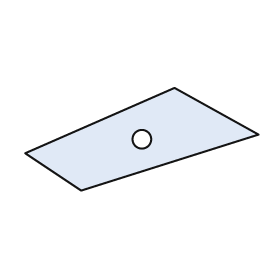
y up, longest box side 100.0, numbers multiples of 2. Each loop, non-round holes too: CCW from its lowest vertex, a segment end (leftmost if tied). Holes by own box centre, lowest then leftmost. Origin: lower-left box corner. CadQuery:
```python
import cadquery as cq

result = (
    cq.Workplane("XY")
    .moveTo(24.0, 0.0)
    .lineTo(100.0, 24.0)
    .lineTo(64.0, 44.0)
    .lineTo(0.0, 16.0)
    .close()
    .moveTo(50.0, 22.0)
    .circle(4.0)
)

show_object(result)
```